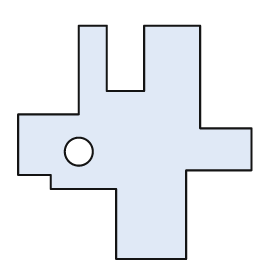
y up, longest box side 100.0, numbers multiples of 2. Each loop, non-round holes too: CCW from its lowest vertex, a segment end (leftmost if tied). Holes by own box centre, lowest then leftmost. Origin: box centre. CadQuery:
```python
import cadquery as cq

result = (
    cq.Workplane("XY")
    .moveTo(-8.0, -50.0)
    .lineTo(22.0, -50.0)
    .lineTo(22.0, -12.0)
    .lineTo(50.0, -12.0)
    .lineTo(50.0, 6.0)
    .lineTo(28.0, 6.0)
    .lineTo(28.0, 50.0)
    .lineTo(4.0, 50.0)
    .lineTo(4.0, 22.0)
    .lineTo(-12.0, 22.0)
    .lineTo(-12.0, 50.0)
    .lineTo(-24.0, 50.0)
    .lineTo(-24.0, 12.0)
    .lineTo(-50.0, 12.0)
    .lineTo(-50.0, -14.0)
    .lineTo(-36.0, -14.0)
    .lineTo(-36.0, -20.0)
    .lineTo(-8.0, -20.0)
    .close()
    .moveTo(-24.0, -4.0)
    .circle(6.0)
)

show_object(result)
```